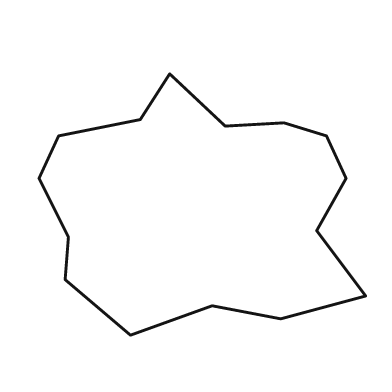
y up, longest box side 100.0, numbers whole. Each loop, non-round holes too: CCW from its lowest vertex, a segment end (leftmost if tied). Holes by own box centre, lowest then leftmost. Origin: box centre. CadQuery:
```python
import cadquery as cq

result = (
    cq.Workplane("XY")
    .moveTo(-22.0, -40.0)
    .lineTo(3.0, -31.0)
    .lineTo(24.0, -35.0)
    .lineTo(50.0, -28.0)
    .lineTo(35.0, -8.0)
    .lineTo(44.0, 8.0)
    .lineTo(38.0, 21.0)
    .lineTo(25.0, 25.0)
    .lineTo(7.0, 24.0)
    .lineTo(-10.0, 40.0)
    .lineTo(-19.0, 26.0)
    .lineTo(-44.0, 21.0)
    .lineTo(-50.0, 8.0)
    .lineTo(-41.0, -10.0)
    .lineTo(-42.0, -23.0)
    .close()
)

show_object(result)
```